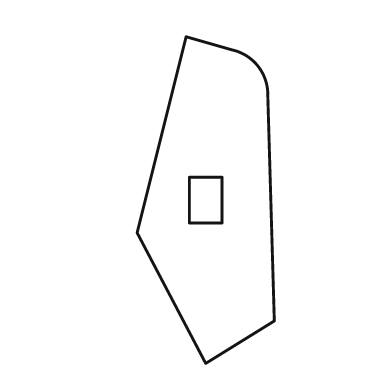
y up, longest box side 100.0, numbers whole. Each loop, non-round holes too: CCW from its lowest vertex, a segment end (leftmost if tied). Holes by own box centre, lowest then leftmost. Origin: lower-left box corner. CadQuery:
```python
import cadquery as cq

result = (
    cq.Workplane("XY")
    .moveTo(21.0, 0.0)
    .lineTo(42.0, 13.0)
    .lineTo(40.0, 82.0)
    .threePointArc((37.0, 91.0), (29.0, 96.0))
    .lineTo(15.0, 100.0)
    .lineTo(0.0, 40.0)
    .close()
    .moveTo(16.0, 43.0)
    .lineTo(26.0, 43.0)
    .lineTo(26.0, 57.0)
    .lineTo(16.0, 57.0)
    .close()
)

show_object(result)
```